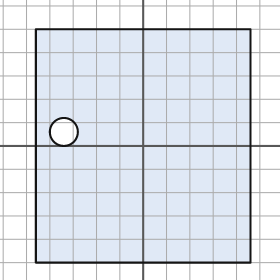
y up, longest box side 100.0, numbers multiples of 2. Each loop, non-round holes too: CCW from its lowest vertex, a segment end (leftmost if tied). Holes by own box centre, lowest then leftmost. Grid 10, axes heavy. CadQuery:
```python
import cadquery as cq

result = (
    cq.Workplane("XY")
    .moveTo(-46.0, -50.0)
    .lineTo(46.0, -50.0)
    .lineTo(46.0, 50.0)
    .lineTo(-46.0, 50.0)
    .close()
    .moveTo(-34.0, 6.0)
    .circle(6.0)
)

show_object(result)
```